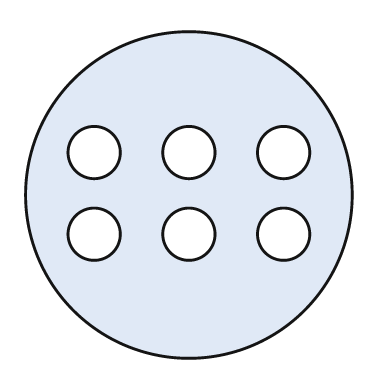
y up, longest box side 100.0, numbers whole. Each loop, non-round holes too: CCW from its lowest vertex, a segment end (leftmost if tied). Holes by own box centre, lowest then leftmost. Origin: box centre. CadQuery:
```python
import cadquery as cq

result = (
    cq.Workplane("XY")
    .moveTo(0.0, 0.0)
    .circle(50.0)
    .moveTo(-29.0, -12.0)
    .circle(8.0)
    .moveTo(0.0, -12.0)
    .circle(8.0)
    .moveTo(29.0, -12.0)
    .circle(8.0)
    .moveTo(-29.0, 13.0)
    .circle(8.0)
    .moveTo(0.0, 13.0)
    .circle(8.0)
    .moveTo(29.0, 13.0)
    .circle(8.0)
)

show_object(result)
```